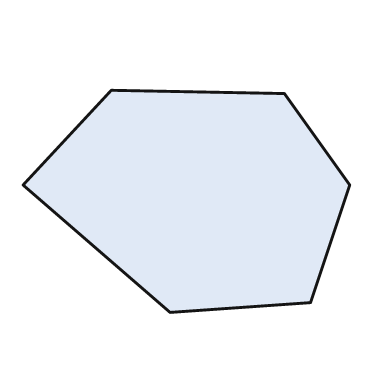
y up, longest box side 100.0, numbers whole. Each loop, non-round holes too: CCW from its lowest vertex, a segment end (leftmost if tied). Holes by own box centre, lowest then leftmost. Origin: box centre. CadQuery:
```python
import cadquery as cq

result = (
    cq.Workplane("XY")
    .moveTo(-5.0, -34.0)
    .lineTo(38.0, -31.0)
    .lineTo(50.0, 5.0)
    .lineTo(30.0, 33.0)
    .lineTo(-23.0, 34.0)
    .lineTo(-50.0, 5.0)
    .close()
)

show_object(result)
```